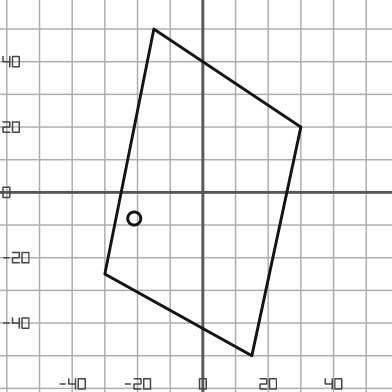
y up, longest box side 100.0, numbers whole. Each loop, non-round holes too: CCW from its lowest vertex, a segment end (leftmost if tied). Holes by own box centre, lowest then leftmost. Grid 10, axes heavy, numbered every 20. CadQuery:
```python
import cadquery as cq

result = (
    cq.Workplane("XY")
    .moveTo(15.0, -50.0)
    .lineTo(30.0, 20.0)
    .lineTo(-15.0, 50.0)
    .lineTo(-30.0, -25.0)
    .close()
    .moveTo(-21.0, -8.0)
    .circle(2.0)
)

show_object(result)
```